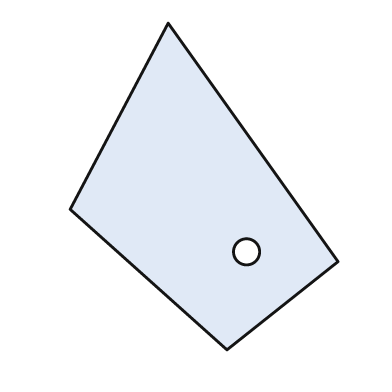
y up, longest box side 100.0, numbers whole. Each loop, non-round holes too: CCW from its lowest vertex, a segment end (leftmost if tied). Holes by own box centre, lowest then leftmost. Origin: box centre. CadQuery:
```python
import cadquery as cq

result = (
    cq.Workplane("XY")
    .moveTo(7.0, -50.0)
    .lineTo(41.0, -23.0)
    .lineTo(-11.0, 50.0)
    .lineTo(-41.0, -7.0)
    .close()
    .moveTo(13.0, -20.0)
    .circle(4.0)
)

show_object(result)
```